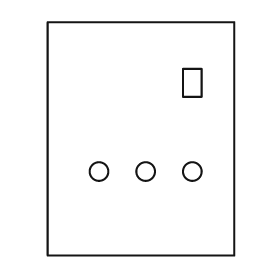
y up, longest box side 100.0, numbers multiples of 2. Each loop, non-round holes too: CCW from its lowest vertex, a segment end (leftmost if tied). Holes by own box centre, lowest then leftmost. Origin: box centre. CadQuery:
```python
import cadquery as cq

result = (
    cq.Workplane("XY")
    .moveTo(-40.0, -50.0)
    .lineTo(40.0, -50.0)
    .lineTo(40.0, 50.0)
    .lineTo(-40.0, 50.0)
    .close()
    .moveTo(-18.0, -14.0)
    .circle(4.0)
    .moveTo(2.0, -14.0)
    .circle(4.0)
    .moveTo(22.0, -14.0)
    .circle(4.0)
    .moveTo(18.0, 18.0)
    .lineTo(26.0, 18.0)
    .lineTo(26.0, 30.0)
    .lineTo(18.0, 30.0)
    .close()
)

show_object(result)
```